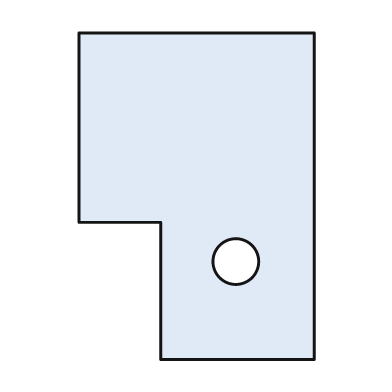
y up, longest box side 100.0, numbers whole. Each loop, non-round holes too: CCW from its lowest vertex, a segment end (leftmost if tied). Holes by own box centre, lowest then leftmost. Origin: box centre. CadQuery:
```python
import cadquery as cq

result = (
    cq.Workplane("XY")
    .moveTo(-11.0, -50.0)
    .lineTo(36.0, -50.0)
    .lineTo(36.0, 50.0)
    .lineTo(-36.0, 50.0)
    .lineTo(-36.0, -8.0)
    .lineTo(-11.0, -8.0)
    .close()
    .moveTo(12.0, -20.0)
    .circle(7.0)
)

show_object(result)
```